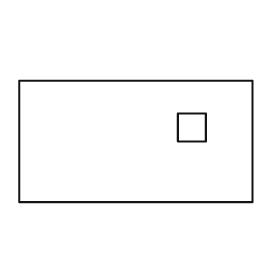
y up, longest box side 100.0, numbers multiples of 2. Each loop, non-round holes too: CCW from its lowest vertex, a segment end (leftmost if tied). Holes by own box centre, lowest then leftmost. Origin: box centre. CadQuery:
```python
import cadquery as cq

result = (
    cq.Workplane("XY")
    .moveTo(-50.0, -26.0)
    .lineTo(50.0, -26.0)
    .lineTo(50.0, 26.0)
    .lineTo(-50.0, 26.0)
    .close()
    .moveTo(18.0, 0.0)
    .lineTo(30.0, 0.0)
    .lineTo(30.0, 12.0)
    .lineTo(18.0, 12.0)
    .close()
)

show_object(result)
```